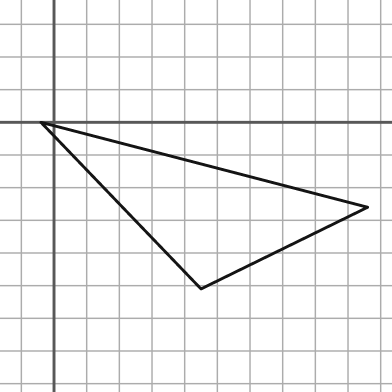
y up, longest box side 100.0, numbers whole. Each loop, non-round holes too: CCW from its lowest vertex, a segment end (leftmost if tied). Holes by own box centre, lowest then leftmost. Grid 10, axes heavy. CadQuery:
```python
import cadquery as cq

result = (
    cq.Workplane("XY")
    .moveTo(45.0, -51.0)
    .lineTo(96.0, -26.0)
    .lineTo(-4.0, 0.0)
    .close()
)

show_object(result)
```